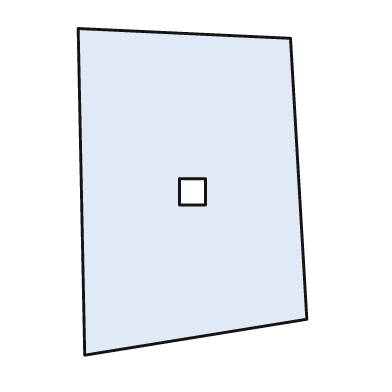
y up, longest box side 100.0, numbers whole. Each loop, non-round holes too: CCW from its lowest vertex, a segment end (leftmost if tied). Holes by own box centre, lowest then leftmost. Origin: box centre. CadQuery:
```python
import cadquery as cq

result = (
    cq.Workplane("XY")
    .moveTo(-33.0, -50.0)
    .lineTo(35.0, -39.0)
    .lineTo(30.0, 47.0)
    .lineTo(-35.0, 50.0)
    .close()
    .moveTo(-4.0, -4.0)
    .lineTo(4.0, -4.0)
    .lineTo(4.0, 4.0)
    .lineTo(-4.0, 4.0)
    .close()
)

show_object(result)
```